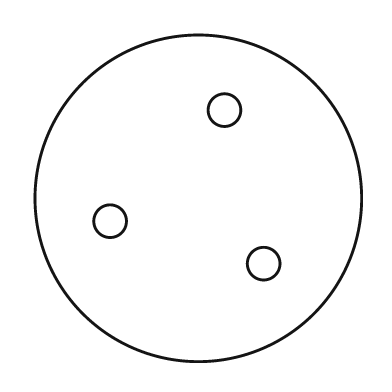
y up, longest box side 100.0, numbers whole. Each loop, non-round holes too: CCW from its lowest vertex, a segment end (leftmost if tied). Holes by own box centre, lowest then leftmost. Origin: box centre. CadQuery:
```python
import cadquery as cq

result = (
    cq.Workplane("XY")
    .moveTo(0.0, 0.0)
    .circle(50.0)
    .moveTo(20.0, -20.0)
    .circle(5.0)
    .moveTo(-27.0, -7.0)
    .circle(5.0)
    .moveTo(8.0, 27.0)
    .circle(5.0)
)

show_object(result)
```